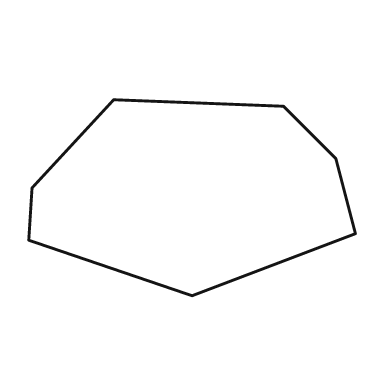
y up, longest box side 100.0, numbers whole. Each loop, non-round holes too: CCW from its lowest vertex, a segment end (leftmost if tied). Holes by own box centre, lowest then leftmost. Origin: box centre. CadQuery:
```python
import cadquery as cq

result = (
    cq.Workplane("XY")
    .moveTo(0.0, -30.0)
    .lineTo(50.0, -11.0)
    .lineTo(44.0, 12.0)
    .lineTo(28.0, 28.0)
    .lineTo(-24.0, 30.0)
    .lineTo(-49.0, 3.0)
    .lineTo(-50.0, -13.0)
    .close()
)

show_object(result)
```